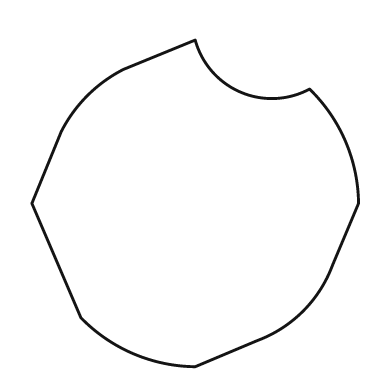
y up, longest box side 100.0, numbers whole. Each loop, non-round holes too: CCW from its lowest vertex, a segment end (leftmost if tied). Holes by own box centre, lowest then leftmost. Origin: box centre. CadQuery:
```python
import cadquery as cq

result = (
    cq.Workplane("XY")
    .moveTo(0.0, -50.0)
    .lineTo(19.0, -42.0)
    .threePointArc((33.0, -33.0), (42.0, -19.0))
    .lineTo(50.0, 0.0)
    .threePointArc((46.0, 19.0), (35.0, 35.0))
    .threePointArc((14.0, 34.0), (0.0, 50.0))
    .lineTo(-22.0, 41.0)
    .threePointArc((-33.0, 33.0), (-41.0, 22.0))
    .lineTo(-50.0, 0.0)
    .lineTo(-35.0, -35.0)
    .threePointArc((-19.0, -46.0), (0.0, -50.0))
    .close()
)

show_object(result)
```